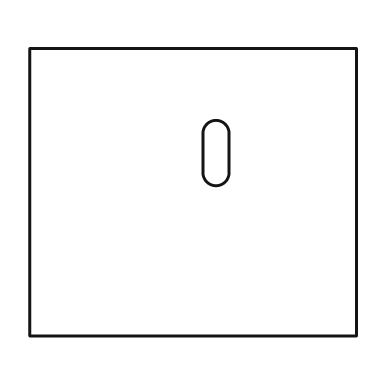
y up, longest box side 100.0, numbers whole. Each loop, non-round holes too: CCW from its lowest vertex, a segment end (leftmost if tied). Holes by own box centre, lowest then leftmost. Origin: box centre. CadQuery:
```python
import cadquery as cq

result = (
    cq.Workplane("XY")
    .moveTo(-50.0, -44.0)
    .lineTo(50.0, -44.0)
    .lineTo(50.0, 44.0)
    .lineTo(-50.0, 44.0)
    .close()
    .moveTo(3.0, 6.0)
    .threePointArc((7.0, 2.0), (11.0, 6.0))
    .lineTo(11.0, 18.0)
    .threePointArc((7.0, 22.0), (3.0, 18.0))
    .close()
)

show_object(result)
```